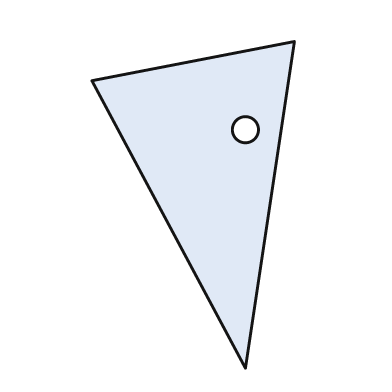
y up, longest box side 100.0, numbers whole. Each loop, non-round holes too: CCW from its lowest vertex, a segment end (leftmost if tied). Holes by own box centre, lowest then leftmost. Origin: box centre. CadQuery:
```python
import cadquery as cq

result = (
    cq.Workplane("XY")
    .moveTo(16.0, -50.0)
    .lineTo(31.0, 50.0)
    .lineTo(-31.0, 38.0)
    .close()
    .moveTo(16.0, 23.0)
    .circle(4.0)
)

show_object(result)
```